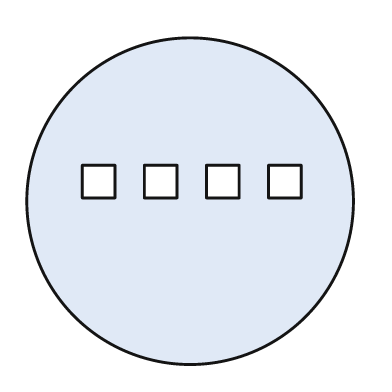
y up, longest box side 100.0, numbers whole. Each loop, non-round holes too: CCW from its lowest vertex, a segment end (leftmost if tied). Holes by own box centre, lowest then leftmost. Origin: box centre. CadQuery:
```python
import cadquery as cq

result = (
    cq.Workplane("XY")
    .moveTo(0.0, 0.0)
    .circle(50.0)
    .moveTo(-33.0, 1.0)
    .lineTo(-23.0, 1.0)
    .lineTo(-23.0, 11.0)
    .lineTo(-33.0, 11.0)
    .close()
    .moveTo(-14.0, 1.0)
    .lineTo(-4.0, 1.0)
    .lineTo(-4.0, 11.0)
    .lineTo(-14.0, 11.0)
    .close()
    .moveTo(5.0, 1.0)
    .lineTo(15.0, 1.0)
    .lineTo(15.0, 11.0)
    .lineTo(5.0, 11.0)
    .close()
    .moveTo(24.0, 1.0)
    .lineTo(34.0, 1.0)
    .lineTo(34.0, 11.0)
    .lineTo(24.0, 11.0)
    .close()
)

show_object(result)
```